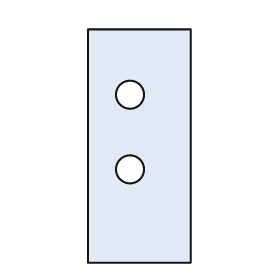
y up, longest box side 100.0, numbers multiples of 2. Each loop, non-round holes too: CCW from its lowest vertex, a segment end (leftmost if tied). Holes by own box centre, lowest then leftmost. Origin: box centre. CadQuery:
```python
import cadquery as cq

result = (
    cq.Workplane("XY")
    .moveTo(-22.0, -50.0)
    .lineTo(22.0, -50.0)
    .lineTo(22.0, 50.0)
    .lineTo(-22.0, 50.0)
    .close()
    .moveTo(-4.0, -10.0)
    .circle(6.0)
    .moveTo(-4.0, 22.0)
    .circle(6.0)
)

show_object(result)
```